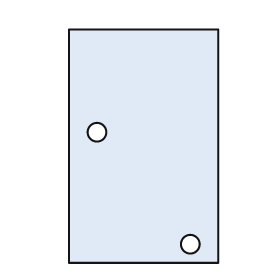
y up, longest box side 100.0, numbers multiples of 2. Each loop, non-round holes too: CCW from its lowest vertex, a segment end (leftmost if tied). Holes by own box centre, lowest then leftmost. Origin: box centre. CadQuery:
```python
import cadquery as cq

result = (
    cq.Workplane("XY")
    .moveTo(-32.0, -50.0)
    .lineTo(32.0, -50.0)
    .lineTo(32.0, 50.0)
    .lineTo(-32.0, 50.0)
    .close()
    .moveTo(20.0, -42.0)
    .circle(4.0)
    .moveTo(-20.0, 6.0)
    .circle(4.0)
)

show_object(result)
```